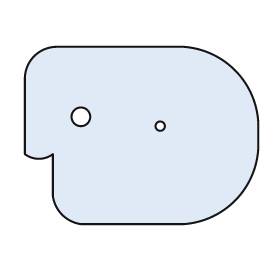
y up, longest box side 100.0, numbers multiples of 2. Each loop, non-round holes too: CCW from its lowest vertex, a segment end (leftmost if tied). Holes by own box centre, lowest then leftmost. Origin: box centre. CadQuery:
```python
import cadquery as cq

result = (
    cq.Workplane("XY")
    .moveTo(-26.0, -38.0)
    .lineTo(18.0, -38.0)
    .threePointArc((40.0, -28.0), (50.0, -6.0))
    .lineTo(50.0, 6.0)
    .threePointArc((40.0, 28.0), (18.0, 38.0))
    .lineTo(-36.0, 38.0)
    .threePointArc((-46.0, 34.0), (-50.0, 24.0))
    .lineTo(-50.0, -8.0)
    .threePointArc((-44.0, -10.0), (-38.0, -8.0))
    .lineTo(-38.0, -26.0)
    .threePointArc((-34.0, -34.0), (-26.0, -38.0))
    .close()
    .moveTo(8.0, 4.0)
    .circle(2.0)
    .moveTo(-26.0, 8.0)
    .circle(4.0)
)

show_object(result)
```